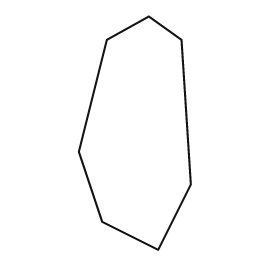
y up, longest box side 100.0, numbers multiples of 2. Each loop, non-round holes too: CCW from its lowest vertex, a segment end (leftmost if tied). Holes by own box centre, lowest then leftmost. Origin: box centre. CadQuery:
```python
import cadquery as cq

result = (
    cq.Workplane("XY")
    .moveTo(10.0, -50.0)
    .lineTo(24.0, -22.0)
    .lineTo(20.0, 40.0)
    .lineTo(6.0, 50.0)
    .lineTo(-12.0, 40.0)
    .lineTo(-24.0, -8.0)
    .lineTo(-14.0, -38.0)
    .close()
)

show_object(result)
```